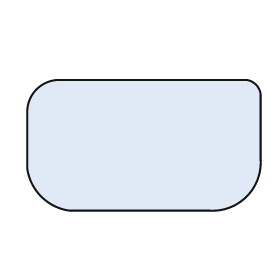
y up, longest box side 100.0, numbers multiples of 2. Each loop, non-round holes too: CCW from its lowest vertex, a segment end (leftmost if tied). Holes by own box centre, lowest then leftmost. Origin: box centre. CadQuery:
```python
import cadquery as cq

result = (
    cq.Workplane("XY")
    .moveTo(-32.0, -28.0)
    .lineTo(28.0, -28.0)
    .threePointArc((44.0, -22.0), (50.0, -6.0))
    .lineTo(50.0, 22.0)
    .threePointArc((48.0, 26.0), (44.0, 28.0))
    .lineTo(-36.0, 28.0)
    .threePointArc((-46.0, 24.0), (-50.0, 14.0))
    .lineTo(-50.0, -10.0)
    .threePointArc((-44.0, -22.0), (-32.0, -28.0))
    .close()
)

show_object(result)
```